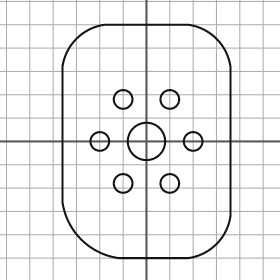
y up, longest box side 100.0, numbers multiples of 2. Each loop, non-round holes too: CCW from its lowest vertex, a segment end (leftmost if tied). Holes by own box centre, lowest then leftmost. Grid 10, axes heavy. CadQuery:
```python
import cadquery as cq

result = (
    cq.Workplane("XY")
    .moveTo(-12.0, -50.0)
    .lineTo(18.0, -50.0)
    .threePointArc((30.0, -44.0), (36.0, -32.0))
    .lineTo(36.0, 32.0)
    .threePointArc((30.0, 44.0), (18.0, 50.0))
    .lineTo(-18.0, 50.0)
    .threePointArc((-30.0, 44.0), (-36.0, 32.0))
    .lineTo(-36.0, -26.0)
    .threePointArc((-28.0, -42.0), (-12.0, -50.0))
    .close()
    .moveTo(-10.0, -18.0)
    .circle(4.0)
    .moveTo(10.0, -18.0)
    .circle(4.0)
    .moveTo(-20.0, 0.0)
    .circle(4.0)
    .moveTo(0.0, 0.0)
    .circle(8.0)
    .moveTo(20.0, 0.0)
    .circle(4.0)
    .moveTo(-10.0, 18.0)
    .circle(4.0)
    .moveTo(10.0, 18.0)
    .circle(4.0)
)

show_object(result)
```